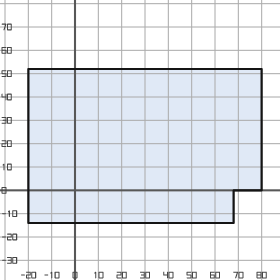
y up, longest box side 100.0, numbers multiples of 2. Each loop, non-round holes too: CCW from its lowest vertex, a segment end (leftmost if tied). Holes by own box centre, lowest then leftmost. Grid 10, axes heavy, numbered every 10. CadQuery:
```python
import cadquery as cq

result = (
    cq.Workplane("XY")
    .moveTo(-20.0, -14.0)
    .lineTo(68.0, -14.0)
    .lineTo(68.0, 0.0)
    .lineTo(80.0, 0.0)
    .lineTo(80.0, 52.0)
    .lineTo(-20.0, 52.0)
    .close()
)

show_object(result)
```